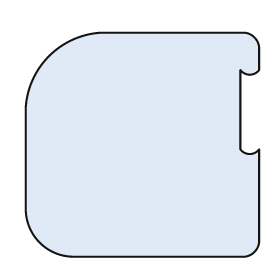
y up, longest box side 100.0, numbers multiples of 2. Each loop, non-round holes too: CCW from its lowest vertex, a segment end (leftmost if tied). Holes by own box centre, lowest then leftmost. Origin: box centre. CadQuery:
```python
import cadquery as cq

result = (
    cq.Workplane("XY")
    .moveTo(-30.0, -48.0)
    .lineTo(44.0, -48.0)
    .threePointArc((48.0, -46.0), (50.0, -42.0))
    .lineTo(50.0, -2.0)
    .threePointArc((46.0, -4.0), (42.0, -2.0))
    .lineTo(42.0, 32.0)
    .threePointArc((46.0, 30.0), (50.0, 32.0))
    .lineTo(50.0, 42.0)
    .threePointArc((48.0, 46.0), (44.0, 48.0))
    .lineTo(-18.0, 48.0)
    .threePointArc((-40.0, 38.0), (-50.0, 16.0))
    .lineTo(-50.0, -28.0)
    .threePointArc((-44.0, -42.0), (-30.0, -48.0))
    .close()
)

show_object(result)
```